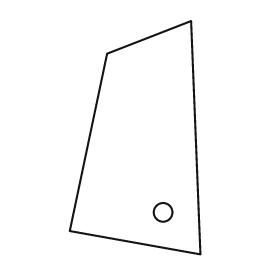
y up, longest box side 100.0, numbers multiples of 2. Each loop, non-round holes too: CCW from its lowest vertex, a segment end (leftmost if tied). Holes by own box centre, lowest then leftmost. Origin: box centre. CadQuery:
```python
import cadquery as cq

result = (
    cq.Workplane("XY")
    .moveTo(28.0, -50.0)
    .lineTo(24.0, 50.0)
    .lineTo(-12.0, 36.0)
    .lineTo(-28.0, -40.0)
    .close()
    .moveTo(12.0, -32.0)
    .circle(4.0)
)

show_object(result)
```